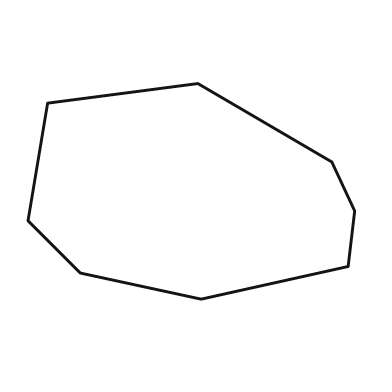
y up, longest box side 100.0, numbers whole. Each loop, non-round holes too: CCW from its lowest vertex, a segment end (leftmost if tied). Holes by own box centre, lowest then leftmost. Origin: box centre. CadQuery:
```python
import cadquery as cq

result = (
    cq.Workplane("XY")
    .moveTo(3.0, -33.0)
    .lineTo(48.0, -23.0)
    .lineTo(50.0, -6.0)
    .lineTo(43.0, 9.0)
    .lineTo(2.0, 33.0)
    .lineTo(-44.0, 27.0)
    .lineTo(-50.0, -9.0)
    .lineTo(-34.0, -25.0)
    .close()
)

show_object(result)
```